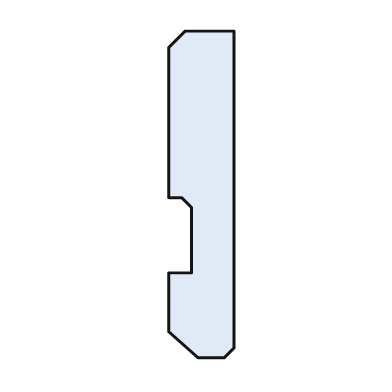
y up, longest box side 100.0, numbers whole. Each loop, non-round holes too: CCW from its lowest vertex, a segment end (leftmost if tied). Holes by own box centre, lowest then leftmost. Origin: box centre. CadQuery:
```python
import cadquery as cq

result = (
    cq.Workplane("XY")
    .moveTo(-1.0, -50.0)
    .lineTo(7.0, -50.0)
    .lineTo(10.0, -47.0)
    .lineTo(10.0, 50.0)
    .lineTo(-5.0, 50.0)
    .lineTo(-10.0, 45.0)
    .lineTo(-10.0, -1.0)
    .lineTo(-6.0, -1.0)
    .lineTo(-3.0, -4.0)
    .lineTo(-3.0, -24.0)
    .lineTo(-10.0, -24.0)
    .lineTo(-10.0, -42.0)
    .close()
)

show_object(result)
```